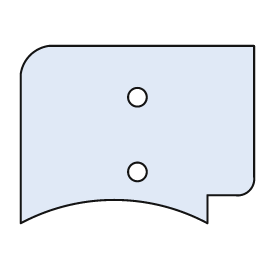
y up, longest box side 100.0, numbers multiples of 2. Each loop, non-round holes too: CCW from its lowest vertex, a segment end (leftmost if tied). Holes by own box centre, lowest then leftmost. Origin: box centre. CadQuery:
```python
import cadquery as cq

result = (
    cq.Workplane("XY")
    .moveTo(-50.0, -38.0)
    .threePointArc((-10.0, -28.0), (30.0, -38.0))
    .lineTo(30.0, -26.0)
    .lineTo(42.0, -26.0)
    .threePointArc((48.0, -24.0), (50.0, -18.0))
    .lineTo(50.0, 38.0)
    .lineTo(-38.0, 38.0)
    .threePointArc((-46.0, 34.0), (-50.0, 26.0))
    .close()
    .moveTo(0.0, -16.0)
    .circle(4.0)
    .moveTo(0.0, 16.0)
    .circle(4.0)
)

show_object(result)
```